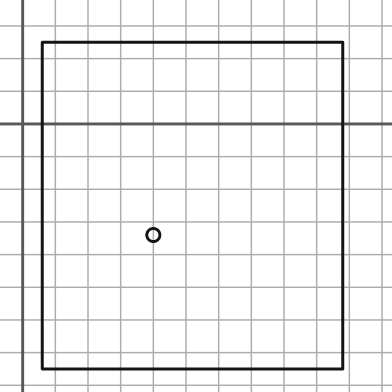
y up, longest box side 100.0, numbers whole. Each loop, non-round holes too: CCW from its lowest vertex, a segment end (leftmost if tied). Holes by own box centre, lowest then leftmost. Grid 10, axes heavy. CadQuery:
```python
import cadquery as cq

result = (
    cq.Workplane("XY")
    .moveTo(6.0, -75.0)
    .lineTo(98.0, -75.0)
    .lineTo(98.0, 25.0)
    .lineTo(6.0, 25.0)
    .close()
    .moveTo(40.0, -34.0)
    .circle(2.0)
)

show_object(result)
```